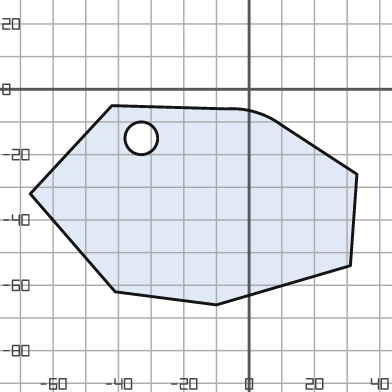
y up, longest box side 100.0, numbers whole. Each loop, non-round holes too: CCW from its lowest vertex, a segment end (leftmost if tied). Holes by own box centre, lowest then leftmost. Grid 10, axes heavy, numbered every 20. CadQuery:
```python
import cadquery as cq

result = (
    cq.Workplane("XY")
    .moveTo(-10.0, -66.0)
    .lineTo(31.0, -54.0)
    .lineTo(33.0, -26.0)
    .lineTo(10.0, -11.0)
    .threePointArc((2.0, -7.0), (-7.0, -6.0))
    .lineTo(-42.0, -5.0)
    .lineTo(-67.0, -32.0)
    .lineTo(-41.0, -62.0)
    .close()
    .moveTo(-33.0, -15.0)
    .circle(5.0)
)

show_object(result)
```